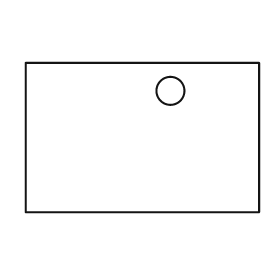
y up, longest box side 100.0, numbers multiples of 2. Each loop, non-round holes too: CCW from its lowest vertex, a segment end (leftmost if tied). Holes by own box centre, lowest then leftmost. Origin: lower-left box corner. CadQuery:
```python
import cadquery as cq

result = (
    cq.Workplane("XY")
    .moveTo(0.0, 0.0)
    .lineTo(100.0, 0.0)
    .lineTo(100.0, 64.0)
    .lineTo(0.0, 64.0)
    .close()
    .moveTo(62.0, 52.0)
    .circle(6.0)
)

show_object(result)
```